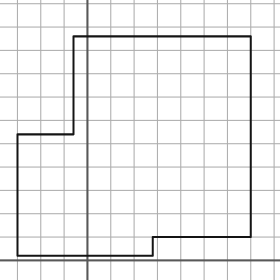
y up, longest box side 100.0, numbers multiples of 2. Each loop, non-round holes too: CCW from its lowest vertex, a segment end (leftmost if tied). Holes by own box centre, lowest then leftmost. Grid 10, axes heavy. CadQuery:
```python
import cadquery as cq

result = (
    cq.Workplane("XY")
    .moveTo(-30.0, 2.0)
    .lineTo(28.0, 2.0)
    .lineTo(28.0, 10.0)
    .lineTo(70.0, 10.0)
    .lineTo(70.0, 96.0)
    .lineTo(-6.0, 96.0)
    .lineTo(-6.0, 54.0)
    .lineTo(-30.0, 54.0)
    .close()
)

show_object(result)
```